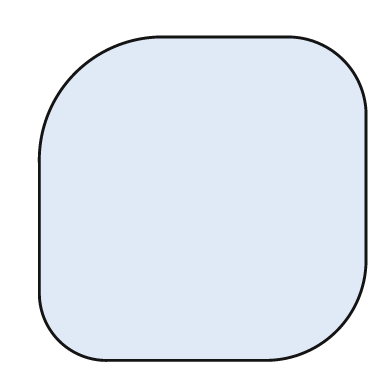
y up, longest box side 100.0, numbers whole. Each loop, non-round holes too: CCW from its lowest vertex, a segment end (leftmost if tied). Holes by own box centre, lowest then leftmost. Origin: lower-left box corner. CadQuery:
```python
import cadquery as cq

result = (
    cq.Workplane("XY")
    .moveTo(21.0, 0.0)
    .lineTo(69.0, 0.0)
    .threePointArc((91.0, 9.0), (100.0, 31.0))
    .lineTo(100.0, 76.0)
    .threePointArc((93.0, 92.0), (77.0, 99.0))
    .lineTo(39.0, 99.0)
    .threePointArc((11.0, 88.0), (0.0, 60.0))
    .lineTo(0.0, 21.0)
    .threePointArc((6.0, 6.0), (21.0, 0.0))
    .close()
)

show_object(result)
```